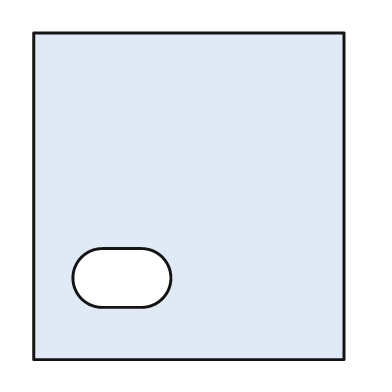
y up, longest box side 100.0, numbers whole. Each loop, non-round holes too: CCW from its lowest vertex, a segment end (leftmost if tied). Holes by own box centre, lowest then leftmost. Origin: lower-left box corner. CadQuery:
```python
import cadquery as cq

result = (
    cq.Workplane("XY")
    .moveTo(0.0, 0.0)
    .lineTo(95.0, 0.0)
    .lineTo(95.0, 100.0)
    .lineTo(0.0, 100.0)
    .close()
    .moveTo(21.0, 16.0)
    .lineTo(33.0, 16.0)
    .threePointArc((42.0, 25.0), (33.0, 34.0))
    .lineTo(21.0, 34.0)
    .threePointArc((12.0, 25.0), (21.0, 16.0))
    .close()
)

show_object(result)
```